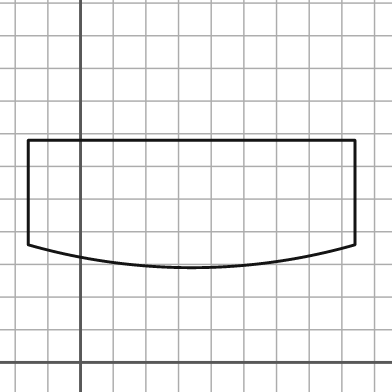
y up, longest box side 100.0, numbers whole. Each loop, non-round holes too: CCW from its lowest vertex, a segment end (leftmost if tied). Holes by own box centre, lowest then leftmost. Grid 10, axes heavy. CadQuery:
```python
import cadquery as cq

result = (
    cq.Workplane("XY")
    .moveTo(-16.0, 36.0)
    .threePointArc((34.0, 29.0), (84.0, 36.0))
    .lineTo(84.0, 68.0)
    .lineTo(-16.0, 68.0)
    .close()
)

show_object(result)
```